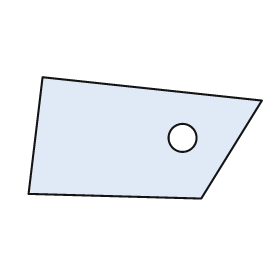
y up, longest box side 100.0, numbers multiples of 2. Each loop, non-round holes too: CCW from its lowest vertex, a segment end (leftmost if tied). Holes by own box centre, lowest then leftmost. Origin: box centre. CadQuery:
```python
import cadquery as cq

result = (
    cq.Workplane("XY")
    .moveTo(24.0, -26.0)
    .lineTo(50.0, 16.0)
    .lineTo(-44.0, 26.0)
    .lineTo(-50.0, -24.0)
    .close()
    .moveTo(16.0, 0.0)
    .circle(6.0)
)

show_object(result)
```